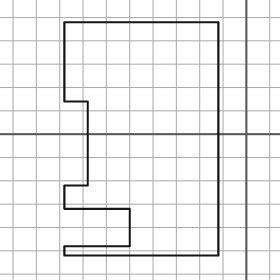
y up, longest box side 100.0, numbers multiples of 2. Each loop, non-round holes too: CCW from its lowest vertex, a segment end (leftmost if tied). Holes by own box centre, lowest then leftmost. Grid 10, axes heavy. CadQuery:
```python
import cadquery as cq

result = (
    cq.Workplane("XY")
    .moveTo(-78.0, -52.0)
    .lineTo(-12.0, -52.0)
    .lineTo(-12.0, 48.0)
    .lineTo(-78.0, 48.0)
    .lineTo(-78.0, 14.0)
    .lineTo(-68.0, 14.0)
    .lineTo(-68.0, -22.0)
    .lineTo(-78.0, -22.0)
    .lineTo(-78.0, -32.0)
    .lineTo(-50.0, -32.0)
    .lineTo(-50.0, -48.0)
    .lineTo(-78.0, -48.0)
    .close()
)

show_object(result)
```